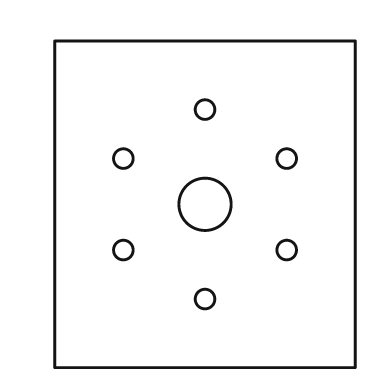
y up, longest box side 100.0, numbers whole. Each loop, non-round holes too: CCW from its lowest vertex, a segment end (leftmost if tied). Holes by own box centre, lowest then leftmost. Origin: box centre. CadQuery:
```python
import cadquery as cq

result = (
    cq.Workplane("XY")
    .moveTo(-46.0, -50.0)
    .lineTo(46.0, -50.0)
    .lineTo(46.0, 50.0)
    .lineTo(-46.0, 50.0)
    .close()
    .moveTo(0.0, -29.0)
    .circle(3.0)
    .moveTo(-25.0, -14.0)
    .circle(3.0)
    .moveTo(25.0, -14.0)
    .circle(3.0)
    .moveTo(0.0, 0.0)
    .circle(8.0)
    .moveTo(-25.0, 14.0)
    .circle(3.0)
    .moveTo(25.0, 14.0)
    .circle(3.0)
    .moveTo(0.0, 29.0)
    .circle(3.0)
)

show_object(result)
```